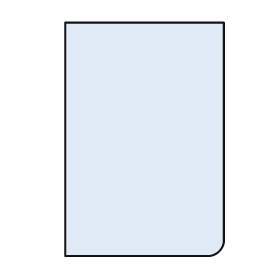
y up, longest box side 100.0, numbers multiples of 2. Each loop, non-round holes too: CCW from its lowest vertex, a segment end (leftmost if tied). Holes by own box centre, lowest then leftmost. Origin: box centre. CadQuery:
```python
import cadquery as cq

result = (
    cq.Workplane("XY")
    .moveTo(-34.0, -50.0)
    .lineTo(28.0, -50.0)
    .threePointArc((32.0, -48.0), (34.0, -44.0))
    .lineTo(34.0, 50.0)
    .lineTo(-34.0, 50.0)
    .close()
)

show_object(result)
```